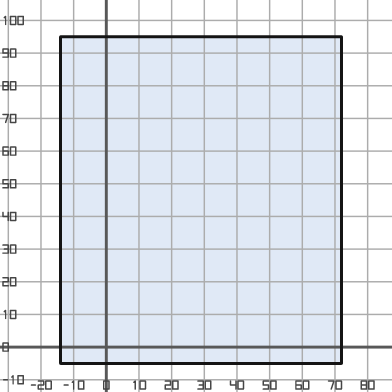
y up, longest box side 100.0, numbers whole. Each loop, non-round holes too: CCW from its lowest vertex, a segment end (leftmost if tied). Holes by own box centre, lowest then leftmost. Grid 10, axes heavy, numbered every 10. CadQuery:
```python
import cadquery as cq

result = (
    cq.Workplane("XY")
    .moveTo(-14.0, -5.0)
    .lineTo(72.0, -5.0)
    .lineTo(72.0, 95.0)
    .lineTo(-14.0, 95.0)
    .close()
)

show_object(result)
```